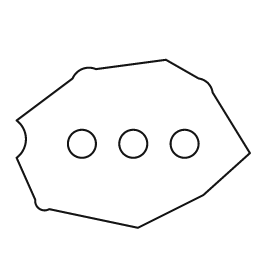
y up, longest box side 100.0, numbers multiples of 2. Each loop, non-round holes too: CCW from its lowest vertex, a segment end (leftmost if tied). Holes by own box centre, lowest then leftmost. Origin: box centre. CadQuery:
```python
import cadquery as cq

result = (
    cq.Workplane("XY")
    .moveTo(2.0, -36.0)
    .lineTo(30.0, -22.0)
    .lineTo(50.0, -4.0)
    .lineTo(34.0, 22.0)
    .threePointArc((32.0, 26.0), (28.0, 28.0))
    .lineTo(14.0, 36.0)
    .lineTo(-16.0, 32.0)
    .threePointArc((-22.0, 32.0), (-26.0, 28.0))
    .lineTo(-50.0, 10.0)
    .threePointArc((-46.0, 2.0), (-50.0, -6.0))
    .lineTo(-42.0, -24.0)
    .threePointArc((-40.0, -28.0), (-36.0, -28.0))
    .close()
    .moveTo(-22.0, 0.0)
    .circle(6.0)
    .moveTo(0.0, 0.0)
    .circle(6.0)
    .moveTo(22.0, 0.0)
    .circle(6.0)
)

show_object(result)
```